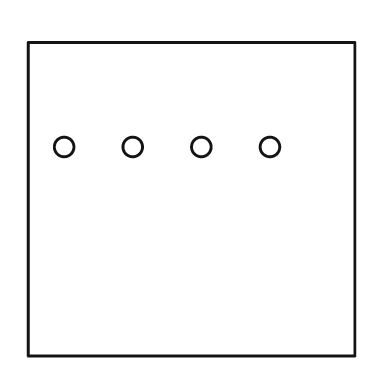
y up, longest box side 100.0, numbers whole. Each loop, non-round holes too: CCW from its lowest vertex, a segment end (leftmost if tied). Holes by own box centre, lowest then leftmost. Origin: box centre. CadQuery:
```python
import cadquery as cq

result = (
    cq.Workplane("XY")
    .moveTo(-50.0, -48.0)
    .lineTo(50.0, -48.0)
    .lineTo(50.0, 48.0)
    .lineTo(-50.0, 48.0)
    .close()
    .moveTo(-39.0, 16.0)
    .circle(3.0)
    .moveTo(-18.0, 16.0)
    .circle(3.0)
    .moveTo(3.0, 16.0)
    .circle(3.0)
    .moveTo(24.0, 16.0)
    .circle(3.0)
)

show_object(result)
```